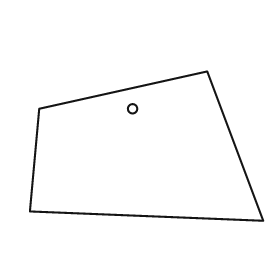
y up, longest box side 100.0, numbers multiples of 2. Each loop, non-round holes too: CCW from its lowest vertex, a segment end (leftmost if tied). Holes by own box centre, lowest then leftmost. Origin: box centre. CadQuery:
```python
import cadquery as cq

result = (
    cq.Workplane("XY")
    .moveTo(50.0, -32.0)
    .lineTo(26.0, 32.0)
    .lineTo(-46.0, 16.0)
    .lineTo(-50.0, -28.0)
    .close()
    .moveTo(-6.0, 16.0)
    .circle(2.0)
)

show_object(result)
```